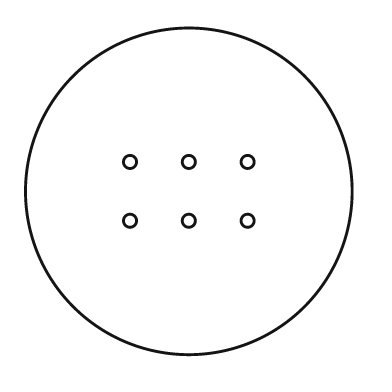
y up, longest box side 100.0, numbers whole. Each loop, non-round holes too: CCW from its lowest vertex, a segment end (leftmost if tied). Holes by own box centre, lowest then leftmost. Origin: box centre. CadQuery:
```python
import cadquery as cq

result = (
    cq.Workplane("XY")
    .moveTo(0.0, 0.0)
    .circle(50.0)
    .moveTo(-18.0, -9.0)
    .circle(2.0)
    .moveTo(0.0, -9.0)
    .circle(2.0)
    .moveTo(18.0, -9.0)
    .circle(2.0)
    .moveTo(-18.0, 9.0)
    .circle(2.0)
    .moveTo(0.0, 9.0)
    .circle(2.0)
    .moveTo(18.0, 9.0)
    .circle(2.0)
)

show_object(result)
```